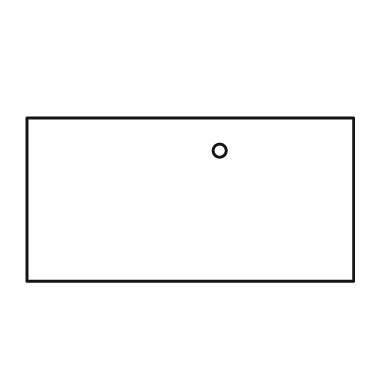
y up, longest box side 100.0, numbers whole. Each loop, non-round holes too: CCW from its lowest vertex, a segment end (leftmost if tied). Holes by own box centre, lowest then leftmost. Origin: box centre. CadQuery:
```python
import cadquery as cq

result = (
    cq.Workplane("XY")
    .moveTo(-50.0, -25.0)
    .lineTo(50.0, -25.0)
    .lineTo(50.0, 25.0)
    .lineTo(-50.0, 25.0)
    .close()
    .moveTo(9.0, 15.0)
    .circle(2.0)
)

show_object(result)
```